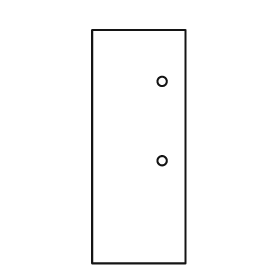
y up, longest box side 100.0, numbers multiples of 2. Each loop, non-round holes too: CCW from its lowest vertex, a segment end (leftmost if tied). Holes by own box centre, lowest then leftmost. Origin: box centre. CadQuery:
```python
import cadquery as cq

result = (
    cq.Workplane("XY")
    .moveTo(-20.0, -50.0)
    .lineTo(20.0, -50.0)
    .lineTo(20.0, 50.0)
    .lineTo(-20.0, 50.0)
    .close()
    .moveTo(10.0, -6.0)
    .circle(2.0)
    .moveTo(10.0, 28.0)
    .circle(2.0)
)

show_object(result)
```